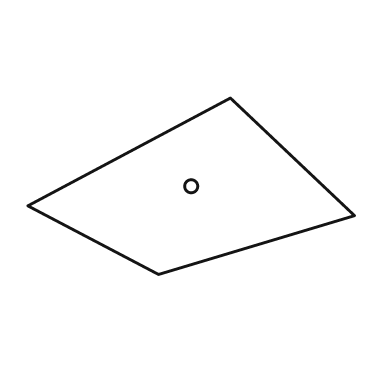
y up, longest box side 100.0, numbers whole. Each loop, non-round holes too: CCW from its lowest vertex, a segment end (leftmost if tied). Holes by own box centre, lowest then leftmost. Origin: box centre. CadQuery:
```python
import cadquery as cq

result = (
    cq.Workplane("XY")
    .moveTo(-10.0, -27.0)
    .lineTo(50.0, -9.0)
    .lineTo(12.0, 27.0)
    .lineTo(-50.0, -6.0)
    .close()
    .moveTo(0.0, 0.0)
    .circle(2.0)
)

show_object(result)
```